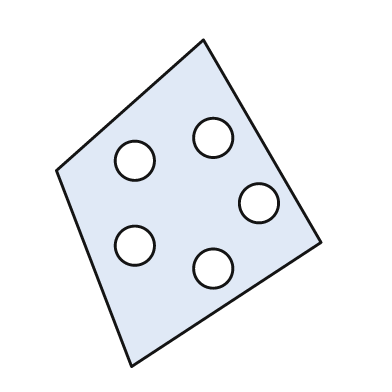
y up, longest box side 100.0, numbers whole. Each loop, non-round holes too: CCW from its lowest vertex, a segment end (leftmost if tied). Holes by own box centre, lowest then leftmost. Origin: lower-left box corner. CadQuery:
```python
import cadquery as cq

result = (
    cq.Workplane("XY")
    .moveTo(23.0, 0.0)
    .lineTo(81.0, 38.0)
    .lineTo(45.0, 100.0)
    .lineTo(0.0, 60.0)
    .close()
    .moveTo(48.0, 30.0)
    .circle(6.0)
    .moveTo(24.0, 37.0)
    .circle(6.0)
    .moveTo(62.0, 50.0)
    .circle(6.0)
    .moveTo(24.0, 63.0)
    .circle(6.0)
    .moveTo(48.0, 70.0)
    .circle(6.0)
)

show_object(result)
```